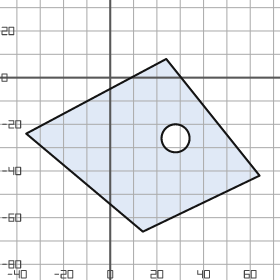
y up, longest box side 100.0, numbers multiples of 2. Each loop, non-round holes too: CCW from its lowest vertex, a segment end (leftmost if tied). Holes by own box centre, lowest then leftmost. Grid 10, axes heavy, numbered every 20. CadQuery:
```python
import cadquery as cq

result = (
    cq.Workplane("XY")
    .moveTo(14.0, -66.0)
    .lineTo(64.0, -42.0)
    .lineTo(24.0, 8.0)
    .lineTo(-36.0, -24.0)
    .close()
    .moveTo(28.0, -26.0)
    .circle(6.0)
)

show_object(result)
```